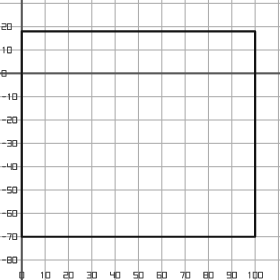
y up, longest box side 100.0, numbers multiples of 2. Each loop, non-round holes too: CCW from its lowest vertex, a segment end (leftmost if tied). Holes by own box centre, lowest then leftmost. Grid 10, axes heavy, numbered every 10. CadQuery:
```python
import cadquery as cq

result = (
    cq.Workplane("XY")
    .moveTo(0.0, -70.0)
    .lineTo(100.0, -70.0)
    .lineTo(100.0, 18.0)
    .lineTo(0.0, 18.0)
    .close()
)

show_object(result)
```